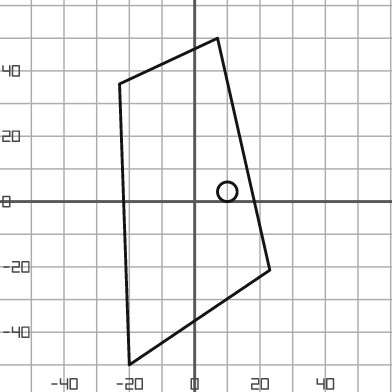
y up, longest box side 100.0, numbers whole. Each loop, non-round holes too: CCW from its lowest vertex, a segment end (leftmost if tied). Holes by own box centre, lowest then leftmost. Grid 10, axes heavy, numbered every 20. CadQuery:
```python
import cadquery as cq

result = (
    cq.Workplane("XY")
    .moveTo(-20.0, -50.0)
    .lineTo(23.0, -21.0)
    .lineTo(7.0, 50.0)
    .lineTo(-23.0, 36.0)
    .close()
    .moveTo(10.0, 3.0)
    .circle(3.0)
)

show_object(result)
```